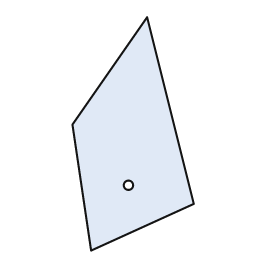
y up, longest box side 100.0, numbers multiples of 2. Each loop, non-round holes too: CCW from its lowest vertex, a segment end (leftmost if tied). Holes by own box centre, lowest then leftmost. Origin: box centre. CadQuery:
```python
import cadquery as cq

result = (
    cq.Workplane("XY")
    .moveTo(-18.0, -50.0)
    .lineTo(26.0, -30.0)
    .lineTo(6.0, 50.0)
    .lineTo(-26.0, 4.0)
    .close()
    .moveTo(-2.0, -22.0)
    .circle(2.0)
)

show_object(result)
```